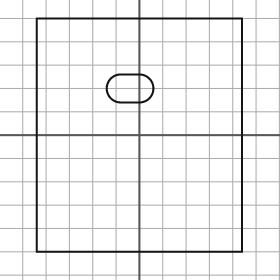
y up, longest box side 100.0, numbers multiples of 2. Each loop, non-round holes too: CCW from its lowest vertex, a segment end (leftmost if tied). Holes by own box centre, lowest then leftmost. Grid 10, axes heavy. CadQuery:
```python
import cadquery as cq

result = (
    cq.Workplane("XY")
    .moveTo(-44.0, -50.0)
    .lineTo(44.0, -50.0)
    .lineTo(44.0, 50.0)
    .lineTo(-44.0, 50.0)
    .close()
    .moveTo(-8.0, 14.0)
    .lineTo(0.0, 14.0)
    .threePointArc((6.0, 20.0), (0.0, 26.0))
    .lineTo(-8.0, 26.0)
    .threePointArc((-14.0, 20.0), (-8.0, 14.0))
    .close()
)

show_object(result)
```